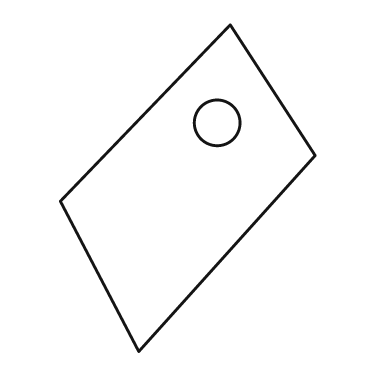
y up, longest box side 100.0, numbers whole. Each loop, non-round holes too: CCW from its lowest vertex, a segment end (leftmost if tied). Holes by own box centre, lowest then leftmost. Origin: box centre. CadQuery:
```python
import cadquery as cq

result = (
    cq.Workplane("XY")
    .moveTo(-15.0, -50.0)
    .lineTo(39.0, 10.0)
    .lineTo(13.0, 50.0)
    .lineTo(-39.0, -4.0)
    .close()
    .moveTo(9.0, 20.0)
    .circle(7.0)
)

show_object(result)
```